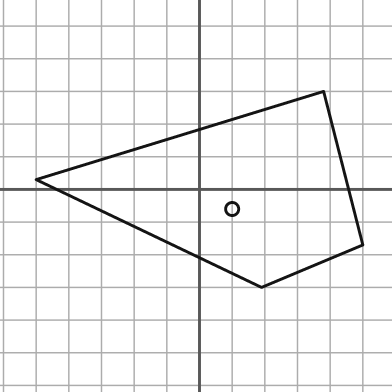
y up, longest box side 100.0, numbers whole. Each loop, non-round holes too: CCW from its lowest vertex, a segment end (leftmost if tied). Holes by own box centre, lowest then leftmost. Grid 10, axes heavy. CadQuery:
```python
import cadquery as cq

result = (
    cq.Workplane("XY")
    .moveTo(19.0, -30.0)
    .lineTo(50.0, -17.0)
    .lineTo(38.0, 30.0)
    .lineTo(-50.0, 3.0)
    .close()
    .moveTo(10.0, -6.0)
    .circle(2.0)
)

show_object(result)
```